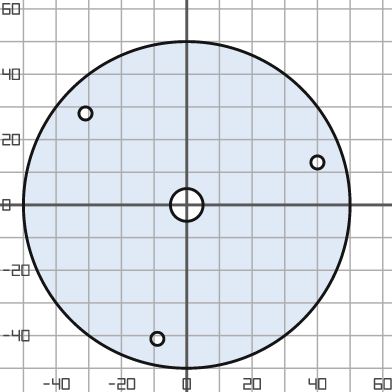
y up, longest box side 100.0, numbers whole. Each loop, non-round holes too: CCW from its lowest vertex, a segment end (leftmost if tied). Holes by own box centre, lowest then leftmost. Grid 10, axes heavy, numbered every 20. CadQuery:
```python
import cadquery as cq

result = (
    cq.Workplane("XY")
    .moveTo(0.0, 0.0)
    .circle(50.0)
    .moveTo(-9.0, -41.0)
    .circle(2.0)
    .moveTo(0.0, 0.0)
    .circle(5.0)
    .moveTo(40.0, 13.0)
    .circle(2.0)
    .moveTo(-31.0, 28.0)
    .circle(2.0)
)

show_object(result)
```